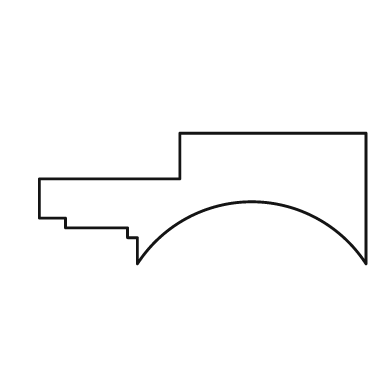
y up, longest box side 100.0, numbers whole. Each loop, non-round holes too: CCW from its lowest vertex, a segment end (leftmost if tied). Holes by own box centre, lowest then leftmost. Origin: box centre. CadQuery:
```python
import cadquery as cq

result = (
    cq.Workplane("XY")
    .moveTo(-20.0, -20.0)
    .threePointArc((15.0, -1.0), (50.0, -20.0))
    .lineTo(50.0, 20.0)
    .lineTo(-7.0, 20.0)
    .lineTo(-7.0, 6.0)
    .lineTo(-50.0, 6.0)
    .lineTo(-50.0, -6.0)
    .lineTo(-42.0, -6.0)
    .lineTo(-42.0, -9.0)
    .lineTo(-23.0, -9.0)
    .lineTo(-23.0, -12.0)
    .lineTo(-20.0, -12.0)
    .close()
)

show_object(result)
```